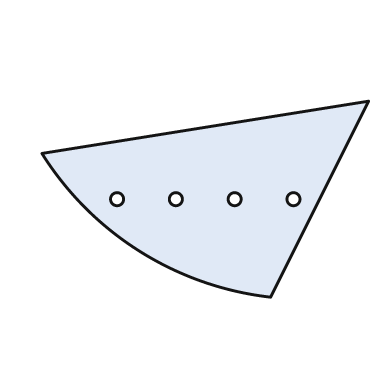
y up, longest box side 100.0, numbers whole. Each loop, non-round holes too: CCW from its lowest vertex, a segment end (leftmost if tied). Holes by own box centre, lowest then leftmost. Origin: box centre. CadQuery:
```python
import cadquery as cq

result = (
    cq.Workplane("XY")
    .moveTo(20.0, -30.0)
    .lineTo(50.0, 30.0)
    .lineTo(-50.0, 14.0)
    .threePointArc((-20.0, -16.0), (20.0, -30.0))
    .close()
    .moveTo(-27.0, 0.0)
    .circle(2.0)
    .moveTo(-9.0, 0.0)
    .circle(2.0)
    .moveTo(9.0, 0.0)
    .circle(2.0)
    .moveTo(27.0, 0.0)
    .circle(2.0)
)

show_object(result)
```